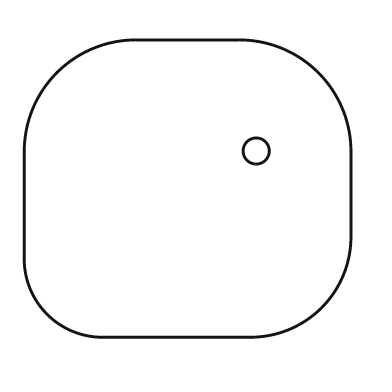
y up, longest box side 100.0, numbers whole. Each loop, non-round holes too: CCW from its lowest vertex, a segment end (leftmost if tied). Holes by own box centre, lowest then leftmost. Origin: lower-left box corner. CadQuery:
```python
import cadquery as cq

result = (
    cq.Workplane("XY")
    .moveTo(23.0, 0.0)
    .lineTo(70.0, 0.0)
    .threePointArc((91.0, 9.0), (100.0, 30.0))
    .lineTo(100.0, 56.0)
    .threePointArc((90.0, 81.0), (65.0, 91.0))
    .lineTo(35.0, 91.0)
    .threePointArc((10.0, 81.0), (0.0, 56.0))
    .lineTo(0.0, 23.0)
    .threePointArc((7.0, 7.0), (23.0, 0.0))
    .close()
    .moveTo(71.0, 57.0)
    .circle(4.0)
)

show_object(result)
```